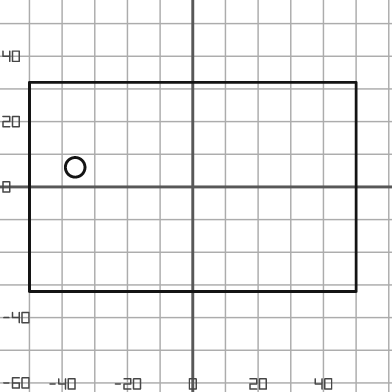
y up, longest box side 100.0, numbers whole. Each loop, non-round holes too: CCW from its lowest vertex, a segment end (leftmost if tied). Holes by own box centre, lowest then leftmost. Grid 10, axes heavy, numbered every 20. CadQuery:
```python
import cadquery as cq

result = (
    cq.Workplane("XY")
    .moveTo(-50.0, -32.0)
    .lineTo(50.0, -32.0)
    .lineTo(50.0, 32.0)
    .lineTo(-50.0, 32.0)
    .close()
    .moveTo(-36.0, 6.0)
    .circle(3.0)
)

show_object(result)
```